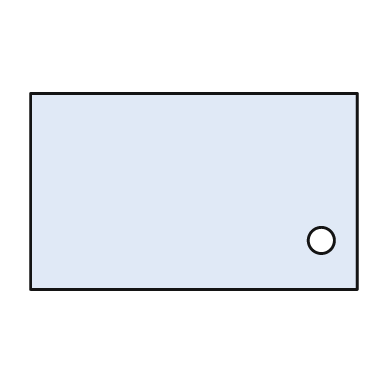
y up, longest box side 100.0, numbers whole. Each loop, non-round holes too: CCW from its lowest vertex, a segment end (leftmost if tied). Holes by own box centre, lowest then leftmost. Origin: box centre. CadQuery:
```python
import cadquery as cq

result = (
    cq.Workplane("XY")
    .moveTo(-50.0, -30.0)
    .lineTo(50.0, -30.0)
    .lineTo(50.0, 30.0)
    .lineTo(-50.0, 30.0)
    .close()
    .moveTo(39.0, -15.0)
    .circle(4.0)
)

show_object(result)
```